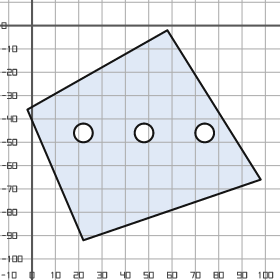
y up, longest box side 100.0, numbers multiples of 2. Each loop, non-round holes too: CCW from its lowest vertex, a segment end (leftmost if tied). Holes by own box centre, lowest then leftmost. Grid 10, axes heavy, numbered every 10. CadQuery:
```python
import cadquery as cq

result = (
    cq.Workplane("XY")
    .moveTo(22.0, -92.0)
    .lineTo(98.0, -66.0)
    .lineTo(58.0, -2.0)
    .lineTo(-2.0, -36.0)
    .close()
    .moveTo(22.0, -46.0)
    .circle(4.0)
    .moveTo(48.0, -46.0)
    .circle(4.0)
    .moveTo(74.0, -46.0)
    .circle(4.0)
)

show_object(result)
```